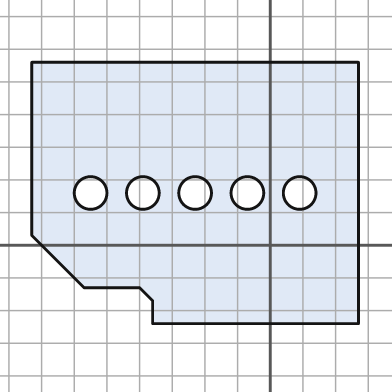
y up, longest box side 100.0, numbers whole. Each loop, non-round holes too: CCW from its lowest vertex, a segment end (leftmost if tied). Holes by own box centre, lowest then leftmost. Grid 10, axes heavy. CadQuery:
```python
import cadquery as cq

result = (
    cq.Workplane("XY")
    .moveTo(-36.0, -24.0)
    .lineTo(27.0, -24.0)
    .lineTo(27.0, 56.0)
    .lineTo(-73.0, 56.0)
    .lineTo(-73.0, 3.0)
    .lineTo(-57.0, -13.0)
    .lineTo(-40.0, -13.0)
    .lineTo(-36.0, -17.0)
    .close()
    .moveTo(-55.0, 16.0)
    .circle(5.0)
    .moveTo(-39.0, 16.0)
    .circle(5.0)
    .moveTo(-23.0, 16.0)
    .circle(5.0)
    .moveTo(-7.0, 16.0)
    .circle(5.0)
    .moveTo(9.0, 16.0)
    .circle(5.0)
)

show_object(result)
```